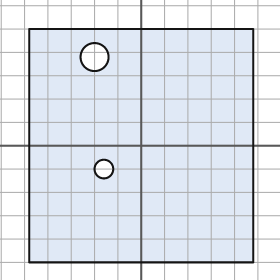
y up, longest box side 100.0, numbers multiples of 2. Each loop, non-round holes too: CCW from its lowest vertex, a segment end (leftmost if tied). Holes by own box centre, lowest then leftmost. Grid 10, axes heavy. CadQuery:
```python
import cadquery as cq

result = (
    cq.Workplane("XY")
    .moveTo(-48.0, -50.0)
    .lineTo(48.0, -50.0)
    .lineTo(48.0, 50.0)
    .lineTo(-48.0, 50.0)
    .close()
    .moveTo(-16.0, -10.0)
    .circle(4.0)
    .moveTo(-20.0, 38.0)
    .circle(6.0)
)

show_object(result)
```